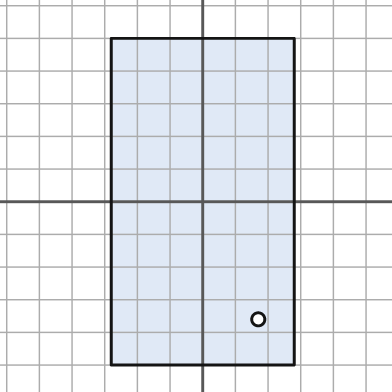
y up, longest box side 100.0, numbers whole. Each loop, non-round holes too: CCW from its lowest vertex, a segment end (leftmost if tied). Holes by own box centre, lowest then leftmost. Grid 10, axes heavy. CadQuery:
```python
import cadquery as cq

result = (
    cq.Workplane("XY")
    .moveTo(-28.0, -50.0)
    .lineTo(28.0, -50.0)
    .lineTo(28.0, 50.0)
    .lineTo(-28.0, 50.0)
    .close()
    .moveTo(17.0, -36.0)
    .circle(2.0)
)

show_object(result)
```